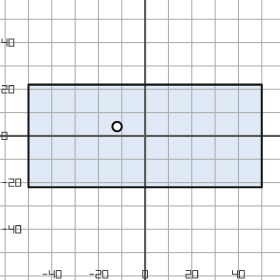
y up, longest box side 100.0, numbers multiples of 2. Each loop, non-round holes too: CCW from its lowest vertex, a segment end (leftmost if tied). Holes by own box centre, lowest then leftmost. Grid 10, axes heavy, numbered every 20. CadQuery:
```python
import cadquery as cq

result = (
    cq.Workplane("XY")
    .moveTo(-50.0, -22.0)
    .lineTo(50.0, -22.0)
    .lineTo(50.0, 22.0)
    .lineTo(-50.0, 22.0)
    .close()
    .moveTo(-12.0, 4.0)
    .circle(2.0)
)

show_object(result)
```